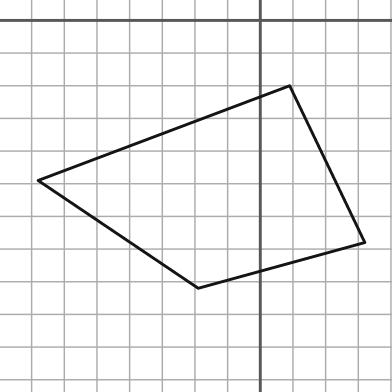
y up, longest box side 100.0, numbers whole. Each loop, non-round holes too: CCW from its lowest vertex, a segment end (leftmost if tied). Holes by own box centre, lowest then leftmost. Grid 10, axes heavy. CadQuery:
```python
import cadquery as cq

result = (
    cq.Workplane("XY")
    .moveTo(-19.0, -82.0)
    .lineTo(32.0, -68.0)
    .lineTo(9.0, -20.0)
    .lineTo(-68.0, -49.0)
    .close()
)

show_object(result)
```